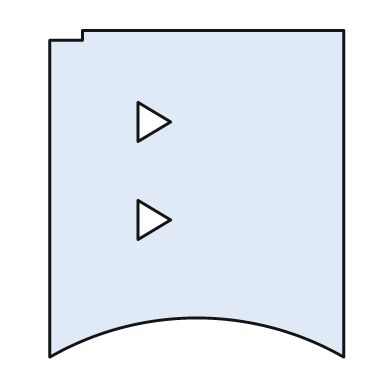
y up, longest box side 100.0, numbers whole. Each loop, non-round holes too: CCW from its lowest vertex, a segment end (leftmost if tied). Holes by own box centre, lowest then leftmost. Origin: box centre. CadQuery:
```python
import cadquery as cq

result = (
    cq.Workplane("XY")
    .moveTo(-45.0, -50.0)
    .threePointArc((0.0, -38.0), (45.0, -50.0))
    .lineTo(45.0, 50.0)
    .lineTo(-35.0, 50.0)
    .lineTo(-35.0, 47.0)
    .lineTo(-45.0, 47.0)
    .close()
    .moveTo(-18.0, -14.0)
    .lineTo(-8.0, -8.0)
    .lineTo(-18.0, -2.0)
    .close()
    .moveTo(-18.0, 16.0)
    .lineTo(-8.0, 22.0)
    .lineTo(-18.0, 28.0)
    .close()
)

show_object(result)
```